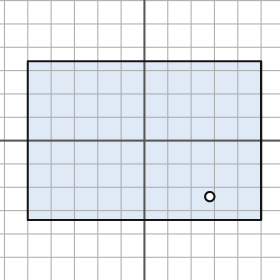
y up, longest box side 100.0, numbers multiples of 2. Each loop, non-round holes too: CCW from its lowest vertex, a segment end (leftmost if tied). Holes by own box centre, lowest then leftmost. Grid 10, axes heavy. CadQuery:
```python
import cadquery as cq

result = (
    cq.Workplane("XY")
    .moveTo(-50.0, -34.0)
    .lineTo(50.0, -34.0)
    .lineTo(50.0, 34.0)
    .lineTo(-50.0, 34.0)
    .close()
    .moveTo(28.0, -24.0)
    .circle(2.0)
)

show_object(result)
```